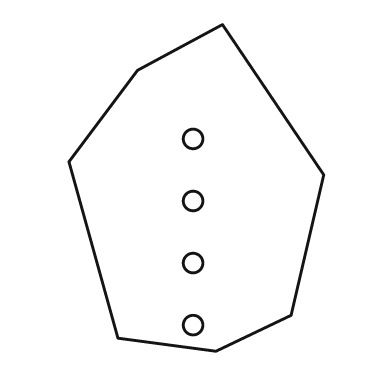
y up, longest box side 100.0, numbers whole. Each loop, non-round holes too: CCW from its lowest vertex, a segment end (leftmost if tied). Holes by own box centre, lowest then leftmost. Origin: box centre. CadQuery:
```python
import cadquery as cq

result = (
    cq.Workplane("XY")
    .moveTo(6.0, -50.0)
    .lineTo(29.0, -39.0)
    .lineTo(39.0, 4.0)
    .lineTo(8.0, 50.0)
    .lineTo(-18.0, 36.0)
    .lineTo(-39.0, 8.0)
    .lineTo(-24.0, -46.0)
    .close()
    .moveTo(-1.0, -42.0)
    .circle(3.0)
    .moveTo(-1.0, -23.0)
    .circle(3.0)
    .moveTo(-1.0, -4.0)
    .circle(3.0)
    .moveTo(-1.0, 15.0)
    .circle(3.0)
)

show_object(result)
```